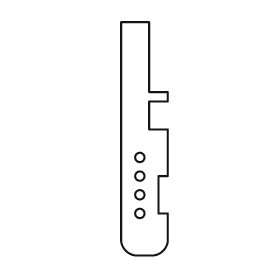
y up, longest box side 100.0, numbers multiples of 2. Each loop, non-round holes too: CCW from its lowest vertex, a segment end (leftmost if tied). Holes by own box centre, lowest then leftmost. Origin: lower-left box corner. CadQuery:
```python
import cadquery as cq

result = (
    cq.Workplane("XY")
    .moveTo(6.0, 0.0)
    .lineTo(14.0, 0.0)
    .threePointArc((18.0, 2.0), (20.0, 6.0))
    .lineTo(20.0, 18.0)
    .lineTo(16.0, 18.0)
    .lineTo(16.0, 34.0)
    .lineTo(20.0, 34.0)
    .lineTo(20.0, 54.0)
    .lineTo(12.0, 54.0)
    .lineTo(12.0, 66.0)
    .lineTo(20.0, 66.0)
    .lineTo(20.0, 70.0)
    .lineTo(12.0, 70.0)
    .lineTo(12.0, 100.0)
    .lineTo(0.0, 100.0)
    .lineTo(0.0, 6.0)
    .threePointArc((2.0, 2.0), (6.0, 0.0))
    .close()
    .moveTo(8.0, 18.0)
    .circle(2.0)
    .moveTo(8.0, 26.0)
    .circle(2.0)
    .moveTo(8.0, 34.0)
    .circle(2.0)
    .moveTo(8.0, 42.0)
    .circle(2.0)
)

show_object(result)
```